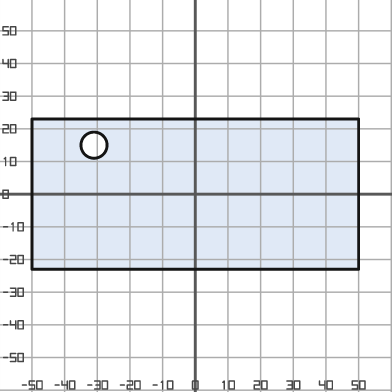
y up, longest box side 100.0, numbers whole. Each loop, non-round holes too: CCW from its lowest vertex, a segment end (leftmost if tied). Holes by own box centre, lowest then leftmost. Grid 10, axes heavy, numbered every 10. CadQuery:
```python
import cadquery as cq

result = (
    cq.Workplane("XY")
    .moveTo(-50.0, -23.0)
    .lineTo(50.0, -23.0)
    .lineTo(50.0, 23.0)
    .lineTo(-50.0, 23.0)
    .close()
    .moveTo(-31.0, 15.0)
    .circle(4.0)
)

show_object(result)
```